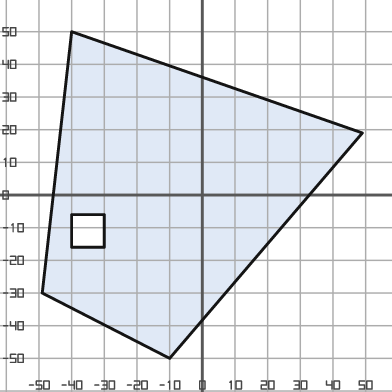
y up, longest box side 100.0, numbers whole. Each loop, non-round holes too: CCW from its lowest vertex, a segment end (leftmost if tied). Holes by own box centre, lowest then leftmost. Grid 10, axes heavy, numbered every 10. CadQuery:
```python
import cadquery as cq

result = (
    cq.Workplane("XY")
    .moveTo(-10.0, -50.0)
    .lineTo(49.0, 19.0)
    .lineTo(-40.0, 50.0)
    .lineTo(-49.0, -30.0)
    .close()
    .moveTo(-40.0, -16.0)
    .lineTo(-30.0, -16.0)
    .lineTo(-30.0, -6.0)
    .lineTo(-40.0, -6.0)
    .close()
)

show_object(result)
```